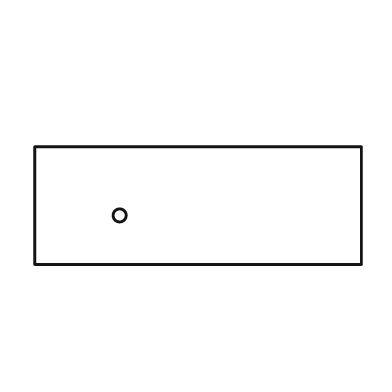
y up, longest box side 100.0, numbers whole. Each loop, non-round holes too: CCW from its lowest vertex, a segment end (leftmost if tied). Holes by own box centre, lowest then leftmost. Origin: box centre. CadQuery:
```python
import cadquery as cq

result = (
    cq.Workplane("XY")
    .moveTo(-50.0, -18.0)
    .lineTo(50.0, -18.0)
    .lineTo(50.0, 18.0)
    .lineTo(-50.0, 18.0)
    .close()
    .moveTo(-24.0, -3.0)
    .circle(2.0)
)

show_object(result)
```